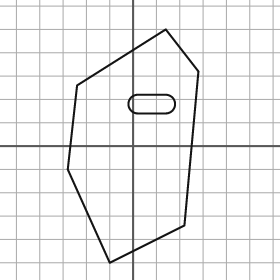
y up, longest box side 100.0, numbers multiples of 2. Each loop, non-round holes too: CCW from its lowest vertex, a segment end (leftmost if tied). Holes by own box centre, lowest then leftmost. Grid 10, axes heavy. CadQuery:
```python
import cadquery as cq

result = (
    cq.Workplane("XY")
    .moveTo(-10.0, -50.0)
    .lineTo(22.0, -34.0)
    .lineTo(28.0, 32.0)
    .lineTo(14.0, 50.0)
    .lineTo(-24.0, 26.0)
    .lineTo(-28.0, -10.0)
    .close()
    .moveTo(2.0, 14.0)
    .lineTo(14.0, 14.0)
    .threePointArc((18.0, 18.0), (14.0, 22.0))
    .lineTo(2.0, 22.0)
    .threePointArc((-2.0, 18.0), (2.0, 14.0))
    .close()
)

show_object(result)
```